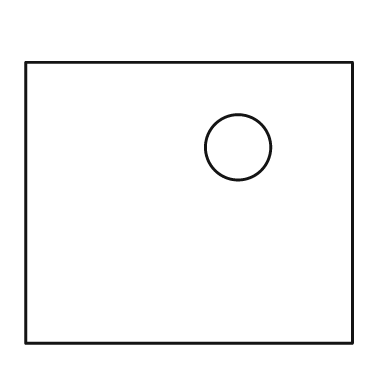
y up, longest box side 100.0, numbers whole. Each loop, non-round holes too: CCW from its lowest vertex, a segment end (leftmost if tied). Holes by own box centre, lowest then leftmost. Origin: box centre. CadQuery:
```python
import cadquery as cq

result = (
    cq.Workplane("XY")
    .moveTo(-50.0, -43.0)
    .lineTo(50.0, -43.0)
    .lineTo(50.0, 43.0)
    .lineTo(-50.0, 43.0)
    .close()
    .moveTo(15.0, 17.0)
    .circle(10.0)
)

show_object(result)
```